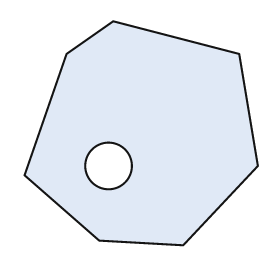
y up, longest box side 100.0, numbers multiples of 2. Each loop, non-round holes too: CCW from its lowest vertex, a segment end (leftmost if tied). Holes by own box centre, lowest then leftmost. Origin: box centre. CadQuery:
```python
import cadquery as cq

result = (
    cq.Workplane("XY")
    .moveTo(18.0, -48.0)
    .lineTo(50.0, -14.0)
    .lineTo(42.0, 34.0)
    .lineTo(-12.0, 48.0)
    .lineTo(-32.0, 34.0)
    .lineTo(-50.0, -18.0)
    .lineTo(-18.0, -46.0)
    .close()
    .moveTo(-14.0, -14.0)
    .circle(10.0)
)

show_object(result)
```